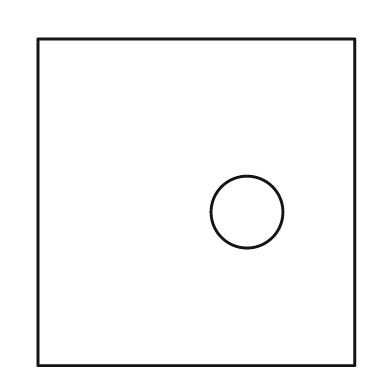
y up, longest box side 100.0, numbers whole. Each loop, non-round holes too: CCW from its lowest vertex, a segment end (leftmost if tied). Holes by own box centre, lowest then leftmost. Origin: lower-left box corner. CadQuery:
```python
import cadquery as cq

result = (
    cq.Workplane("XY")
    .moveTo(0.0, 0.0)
    .lineTo(97.0, 0.0)
    .lineTo(97.0, 100.0)
    .lineTo(0.0, 100.0)
    .close()
    .moveTo(64.0, 47.0)
    .circle(11.0)
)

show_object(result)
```